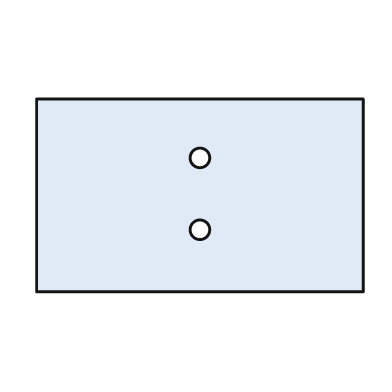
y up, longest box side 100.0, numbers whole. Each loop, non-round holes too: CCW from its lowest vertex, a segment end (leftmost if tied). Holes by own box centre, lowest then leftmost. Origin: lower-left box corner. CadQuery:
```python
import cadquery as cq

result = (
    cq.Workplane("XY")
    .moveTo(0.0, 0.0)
    .lineTo(100.0, 0.0)
    .lineTo(100.0, 59.0)
    .lineTo(0.0, 59.0)
    .close()
    .moveTo(50.0, 19.0)
    .circle(3.0)
    .moveTo(50.0, 41.0)
    .circle(3.0)
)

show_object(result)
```